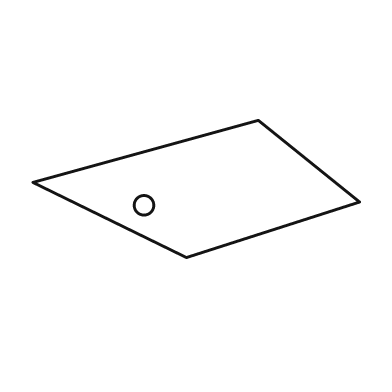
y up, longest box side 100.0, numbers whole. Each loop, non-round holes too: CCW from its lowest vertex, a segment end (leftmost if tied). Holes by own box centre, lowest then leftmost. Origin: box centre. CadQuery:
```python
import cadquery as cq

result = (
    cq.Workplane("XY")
    .moveTo(-3.0, -21.0)
    .lineTo(50.0, -4.0)
    .lineTo(19.0, 21.0)
    .lineTo(-50.0, 2.0)
    .close()
    .moveTo(-16.0, -5.0)
    .circle(3.0)
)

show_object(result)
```